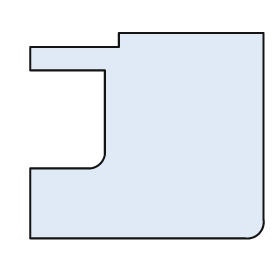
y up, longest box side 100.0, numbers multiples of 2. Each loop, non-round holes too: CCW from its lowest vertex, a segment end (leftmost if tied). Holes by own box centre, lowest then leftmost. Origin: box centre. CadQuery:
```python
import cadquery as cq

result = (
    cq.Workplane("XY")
    .moveTo(-50.0, -44.0)
    .lineTo(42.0, -44.0)
    .threePointArc((48.0, -42.0), (50.0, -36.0))
    .lineTo(50.0, 44.0)
    .lineTo(-12.0, 44.0)
    .lineTo(-12.0, 38.0)
    .lineTo(-50.0, 38.0)
    .lineTo(-50.0, 28.0)
    .lineTo(-18.0, 28.0)
    .lineTo(-18.0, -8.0)
    .threePointArc((-20.0, -12.0), (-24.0, -14.0))
    .lineTo(-50.0, -14.0)
    .close()
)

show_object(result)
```